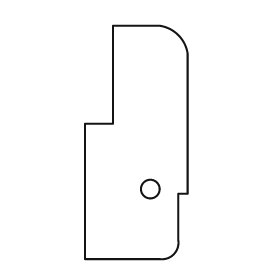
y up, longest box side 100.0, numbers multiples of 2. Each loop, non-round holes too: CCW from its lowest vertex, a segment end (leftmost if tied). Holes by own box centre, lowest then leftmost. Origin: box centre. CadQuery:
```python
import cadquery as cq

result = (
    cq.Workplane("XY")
    .moveTo(-22.0, -50.0)
    .lineTo(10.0, -50.0)
    .threePointArc((16.0, -48.0), (18.0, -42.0))
    .lineTo(18.0, -22.0)
    .lineTo(22.0, -22.0)
    .lineTo(22.0, 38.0)
    .threePointArc((18.0, 46.0), (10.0, 50.0))
    .lineTo(-10.0, 50.0)
    .lineTo(-10.0, 8.0)
    .lineTo(-22.0, 8.0)
    .close()
    .moveTo(6.0, -20.0)
    .circle(4.0)
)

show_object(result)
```